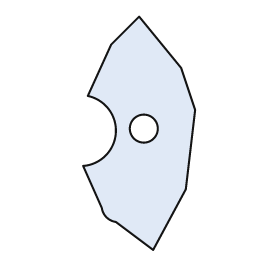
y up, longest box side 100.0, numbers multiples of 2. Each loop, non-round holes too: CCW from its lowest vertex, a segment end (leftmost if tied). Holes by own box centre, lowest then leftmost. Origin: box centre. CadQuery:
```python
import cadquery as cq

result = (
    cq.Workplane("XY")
    .moveTo(6.0, -50.0)
    .lineTo(20.0, -24.0)
    .lineTo(24.0, 10.0)
    .lineTo(18.0, 28.0)
    .lineTo(0.0, 50.0)
    .lineTo(-12.0, 38.0)
    .lineTo(-22.0, 16.0)
    .threePointArc((-10.0, 0.0), (-24.0, -14.0))
    .lineTo(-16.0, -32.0)
    .threePointArc((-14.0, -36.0), (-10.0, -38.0))
    .close()
    .moveTo(2.0, 2.0)
    .circle(6.0)
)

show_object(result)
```